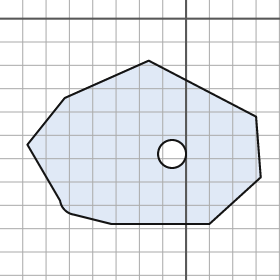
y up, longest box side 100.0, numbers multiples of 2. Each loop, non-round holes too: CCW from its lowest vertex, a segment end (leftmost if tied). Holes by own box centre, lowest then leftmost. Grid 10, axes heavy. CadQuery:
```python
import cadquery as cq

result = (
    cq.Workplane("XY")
    .moveTo(-32.0, -88.0)
    .lineTo(10.0, -88.0)
    .lineTo(32.0, -68.0)
    .lineTo(30.0, -42.0)
    .lineTo(-16.0, -18.0)
    .lineTo(-52.0, -34.0)
    .lineTo(-68.0, -54.0)
    .lineTo(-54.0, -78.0)
    .threePointArc((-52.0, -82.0), (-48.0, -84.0))
    .close()
    .moveTo(-6.0, -58.0)
    .circle(6.0)
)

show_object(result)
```